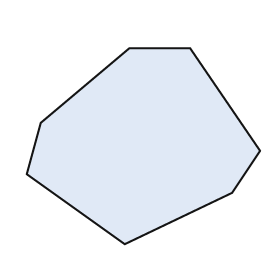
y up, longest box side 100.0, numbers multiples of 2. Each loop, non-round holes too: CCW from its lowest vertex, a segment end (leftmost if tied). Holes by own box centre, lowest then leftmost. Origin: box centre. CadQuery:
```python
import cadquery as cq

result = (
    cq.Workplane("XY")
    .moveTo(-8.0, -42.0)
    .lineTo(38.0, -20.0)
    .lineTo(50.0, -2.0)
    .lineTo(20.0, 42.0)
    .lineTo(-6.0, 42.0)
    .lineTo(-44.0, 10.0)
    .lineTo(-50.0, -12.0)
    .close()
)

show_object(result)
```